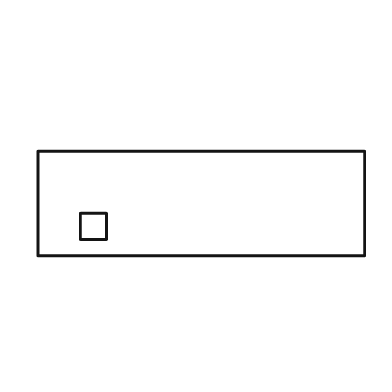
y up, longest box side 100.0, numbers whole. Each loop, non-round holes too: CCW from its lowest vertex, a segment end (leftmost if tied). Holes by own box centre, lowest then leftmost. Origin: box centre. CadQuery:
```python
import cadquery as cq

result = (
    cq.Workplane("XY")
    .moveTo(-50.0, -16.0)
    .lineTo(50.0, -16.0)
    .lineTo(50.0, 16.0)
    .lineTo(-50.0, 16.0)
    .close()
    .moveTo(-37.0, -11.0)
    .lineTo(-29.0, -11.0)
    .lineTo(-29.0, -3.0)
    .lineTo(-37.0, -3.0)
    .close()
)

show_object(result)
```